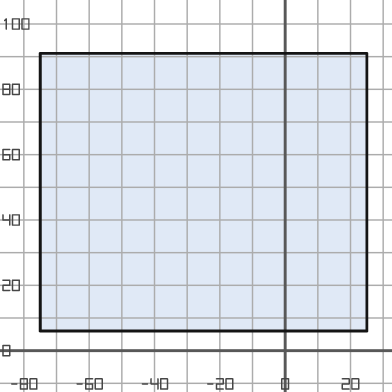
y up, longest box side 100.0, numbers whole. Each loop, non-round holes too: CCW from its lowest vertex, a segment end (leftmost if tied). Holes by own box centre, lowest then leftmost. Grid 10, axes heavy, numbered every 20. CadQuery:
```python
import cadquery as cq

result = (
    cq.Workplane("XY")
    .moveTo(-75.0, 6.0)
    .lineTo(25.0, 6.0)
    .lineTo(25.0, 91.0)
    .lineTo(-75.0, 91.0)
    .close()
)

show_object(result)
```